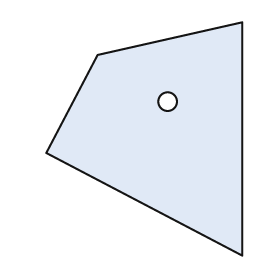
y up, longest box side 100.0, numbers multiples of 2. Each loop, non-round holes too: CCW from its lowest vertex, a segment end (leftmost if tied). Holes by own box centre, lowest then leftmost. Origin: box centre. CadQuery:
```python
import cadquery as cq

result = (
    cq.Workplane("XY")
    .moveTo(42.0, -50.0)
    .lineTo(42.0, 50.0)
    .lineTo(-20.0, 36.0)
    .lineTo(-42.0, -6.0)
    .close()
    .moveTo(10.0, 16.0)
    .circle(4.0)
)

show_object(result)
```